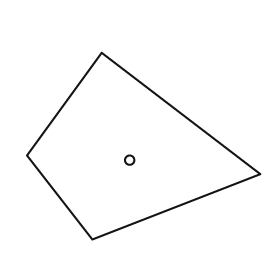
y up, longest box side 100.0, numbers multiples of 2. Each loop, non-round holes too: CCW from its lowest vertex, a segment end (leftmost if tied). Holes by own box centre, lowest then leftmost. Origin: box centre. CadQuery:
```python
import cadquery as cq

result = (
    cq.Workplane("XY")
    .moveTo(-22.0, -40.0)
    .lineTo(50.0, -12.0)
    .lineTo(-18.0, 40.0)
    .lineTo(-50.0, -4.0)
    .close()
    .moveTo(-6.0, -6.0)
    .circle(2.0)
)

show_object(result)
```